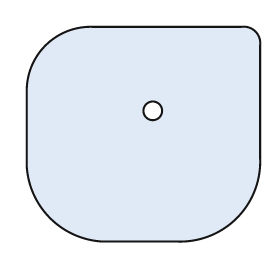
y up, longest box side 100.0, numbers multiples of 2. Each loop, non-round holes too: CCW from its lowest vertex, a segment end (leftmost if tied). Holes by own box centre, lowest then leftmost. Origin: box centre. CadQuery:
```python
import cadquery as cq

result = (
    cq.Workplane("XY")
    .moveTo(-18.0, -46.0)
    .lineTo(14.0, -46.0)
    .threePointArc((40.0, -36.0), (50.0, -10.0))
    .lineTo(50.0, 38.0)
    .threePointArc((48.0, 44.0), (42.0, 46.0))
    .lineTo(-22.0, 46.0)
    .threePointArc((-42.0, 38.0), (-50.0, 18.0))
    .lineTo(-50.0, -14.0)
    .threePointArc((-40.0, -36.0), (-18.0, -46.0))
    .close()
    .moveTo(4.0, 10.0)
    .circle(4.0)
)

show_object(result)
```